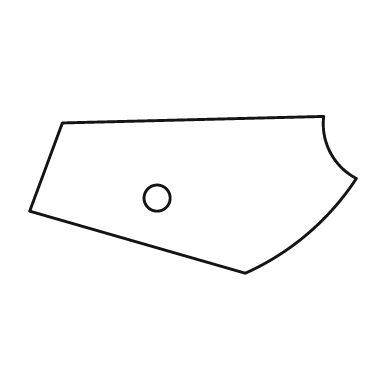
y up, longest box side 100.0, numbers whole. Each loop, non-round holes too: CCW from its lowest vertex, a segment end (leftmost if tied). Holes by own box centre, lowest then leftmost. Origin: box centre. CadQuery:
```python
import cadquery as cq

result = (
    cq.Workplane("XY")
    .moveTo(16.0, -24.0)
    .threePointArc((35.0, -12.0), (50.0, 5.0))
    .threePointArc((42.0, 13.0), (40.0, 24.0))
    .lineTo(-40.0, 22.0)
    .lineTo(-50.0, -5.0)
    .close()
    .moveTo(-11.0, -1.0)
    .circle(4.0)
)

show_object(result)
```